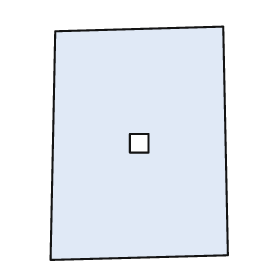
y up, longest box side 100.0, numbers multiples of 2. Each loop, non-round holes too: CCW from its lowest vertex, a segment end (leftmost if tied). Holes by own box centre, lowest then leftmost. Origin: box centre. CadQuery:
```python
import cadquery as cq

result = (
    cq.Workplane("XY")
    .moveTo(-38.0, -50.0)
    .lineTo(38.0, -48.0)
    .lineTo(36.0, 50.0)
    .lineTo(-36.0, 48.0)
    .close()
    .moveTo(-4.0, -4.0)
    .lineTo(4.0, -4.0)
    .lineTo(4.0, 4.0)
    .lineTo(-4.0, 4.0)
    .close()
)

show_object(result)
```